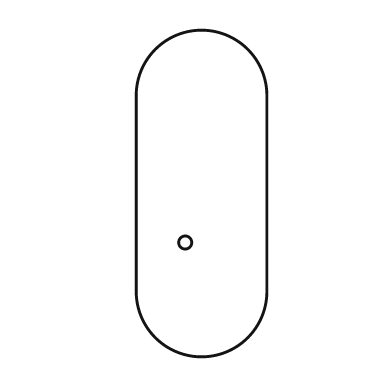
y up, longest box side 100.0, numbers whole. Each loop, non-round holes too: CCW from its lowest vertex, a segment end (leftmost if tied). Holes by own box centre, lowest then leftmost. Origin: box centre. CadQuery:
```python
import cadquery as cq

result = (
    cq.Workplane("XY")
    .moveTo(-20.0, -30.0)
    .threePointArc((0.0, -50.0), (20.0, -30.0))
    .lineTo(20.0, 30.0)
    .threePointArc((0.0, 50.0), (-20.0, 30.0))
    .close()
    .moveTo(-5.0, -15.0)
    .circle(2.0)
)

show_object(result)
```